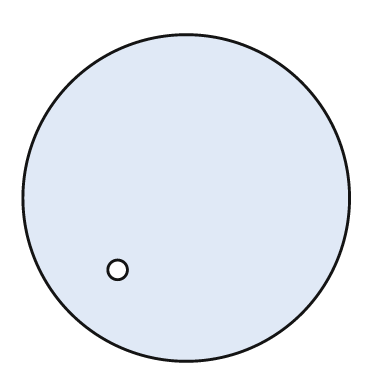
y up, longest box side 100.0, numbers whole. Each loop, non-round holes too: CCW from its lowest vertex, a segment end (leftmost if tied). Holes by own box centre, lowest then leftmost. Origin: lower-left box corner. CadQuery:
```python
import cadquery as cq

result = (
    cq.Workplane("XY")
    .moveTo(50.0, 50.0)
    .circle(50.0)
    .moveTo(29.0, 28.0)
    .circle(3.0)
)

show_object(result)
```